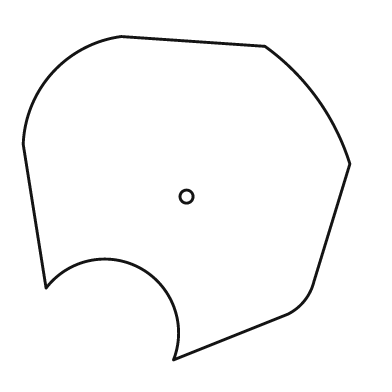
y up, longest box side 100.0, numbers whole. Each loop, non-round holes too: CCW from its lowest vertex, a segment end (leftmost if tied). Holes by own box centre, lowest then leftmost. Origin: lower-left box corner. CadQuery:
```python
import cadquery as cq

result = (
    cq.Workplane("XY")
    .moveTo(46.0, 0.0)
    .lineTo(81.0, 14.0)
    .threePointArc((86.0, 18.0), (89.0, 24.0))
    .lineTo(100.0, 60.0)
    .threePointArc((90.0, 80.0), (74.0, 96.0))
    .lineTo(30.0, 99.0)
    .threePointArc((9.0, 88.0), (0.0, 66.0))
    .lineTo(7.0, 22.0)
    .threePointArc((36.0, 28.0), (46.0, 0.0))
    .close()
    .moveTo(50.0, 50.0)
    .circle(2.0)
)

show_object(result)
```